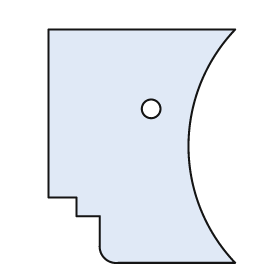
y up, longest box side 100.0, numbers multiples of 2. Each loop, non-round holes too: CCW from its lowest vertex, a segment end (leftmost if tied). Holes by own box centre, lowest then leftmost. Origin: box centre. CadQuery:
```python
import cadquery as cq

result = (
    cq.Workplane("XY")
    .moveTo(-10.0, -50.0)
    .lineTo(40.0, -50.0)
    .threePointArc((20.0, 0.0), (40.0, 50.0))
    .lineTo(-40.0, 50.0)
    .lineTo(-40.0, -22.0)
    .lineTo(-28.0, -22.0)
    .lineTo(-28.0, -30.0)
    .lineTo(-18.0, -30.0)
    .lineTo(-18.0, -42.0)
    .threePointArc((-16.0, -48.0), (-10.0, -50.0))
    .close()
    .moveTo(4.0, 16.0)
    .circle(4.0)
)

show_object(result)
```